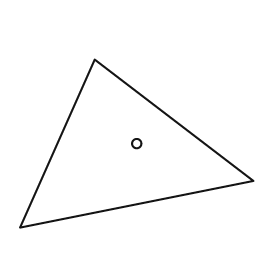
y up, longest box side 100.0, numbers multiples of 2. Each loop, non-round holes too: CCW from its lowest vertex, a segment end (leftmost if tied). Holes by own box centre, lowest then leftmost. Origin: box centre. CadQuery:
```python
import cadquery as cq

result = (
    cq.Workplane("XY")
    .moveTo(-50.0, -36.0)
    .lineTo(50.0, -16.0)
    .lineTo(-18.0, 36.0)
    .close()
    .moveTo(0.0, 0.0)
    .circle(2.0)
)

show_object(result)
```